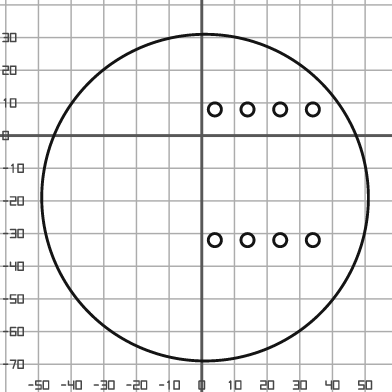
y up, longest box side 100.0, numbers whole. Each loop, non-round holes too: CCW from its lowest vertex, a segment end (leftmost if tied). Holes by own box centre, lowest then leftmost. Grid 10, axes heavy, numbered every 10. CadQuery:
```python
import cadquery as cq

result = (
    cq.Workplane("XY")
    .moveTo(1.0, -19.0)
    .circle(50.0)
    .moveTo(4.0, -32.0)
    .circle(2.0)
    .moveTo(14.0, -32.0)
    .circle(2.0)
    .moveTo(24.0, -32.0)
    .circle(2.0)
    .moveTo(34.0, -32.0)
    .circle(2.0)
    .moveTo(4.0, 8.0)
    .circle(2.0)
    .moveTo(14.0, 8.0)
    .circle(2.0)
    .moveTo(24.0, 8.0)
    .circle(2.0)
    .moveTo(34.0, 8.0)
    .circle(2.0)
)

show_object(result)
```